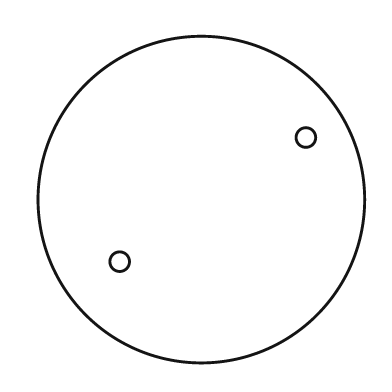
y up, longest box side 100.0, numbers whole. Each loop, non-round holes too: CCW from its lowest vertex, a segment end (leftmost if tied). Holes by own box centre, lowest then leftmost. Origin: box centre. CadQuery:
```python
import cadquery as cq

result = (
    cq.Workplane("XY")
    .moveTo(0.0, 0.0)
    .circle(50.0)
    .moveTo(-25.0, -19.0)
    .circle(3.0)
    .moveTo(32.0, 19.0)
    .circle(3.0)
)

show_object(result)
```